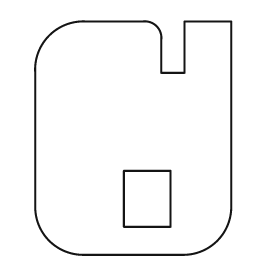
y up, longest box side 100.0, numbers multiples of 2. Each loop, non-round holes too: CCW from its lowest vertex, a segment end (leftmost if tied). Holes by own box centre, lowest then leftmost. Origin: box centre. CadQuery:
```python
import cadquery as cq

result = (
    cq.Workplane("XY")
    .moveTo(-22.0, -50.0)
    .lineTo(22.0, -50.0)
    .threePointArc((36.0, -44.0), (42.0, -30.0))
    .lineTo(42.0, 50.0)
    .lineTo(22.0, 50.0)
    .lineTo(22.0, 28.0)
    .lineTo(12.0, 28.0)
    .lineTo(12.0, 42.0)
    .threePointArc((10.0, 48.0), (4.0, 50.0))
    .lineTo(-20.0, 50.0)
    .threePointArc((-36.0, 44.0), (-42.0, 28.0))
    .lineTo(-42.0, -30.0)
    .threePointArc((-36.0, -44.0), (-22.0, -50.0))
    .close()
    .moveTo(-4.0, -38.0)
    .lineTo(16.0, -38.0)
    .lineTo(16.0, -14.0)
    .lineTo(-4.0, -14.0)
    .close()
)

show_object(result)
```